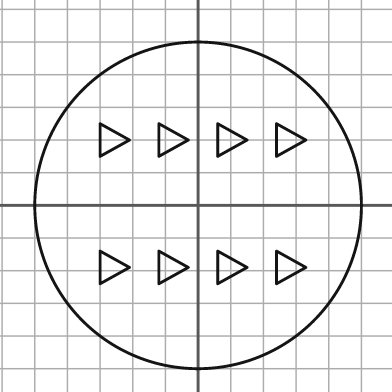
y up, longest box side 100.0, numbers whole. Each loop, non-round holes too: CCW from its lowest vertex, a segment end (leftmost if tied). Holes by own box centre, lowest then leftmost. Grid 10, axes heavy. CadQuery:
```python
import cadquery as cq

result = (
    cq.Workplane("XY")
    .moveTo(0.0, 0.0)
    .circle(50.0)
    .moveTo(-30.0, -24.0)
    .lineTo(-21.0, -19.0)
    .lineTo(-30.0, -14.0)
    .close()
    .moveTo(-12.0, -24.0)
    .lineTo(-3.0, -19.0)
    .lineTo(-12.0, -14.0)
    .close()
    .moveTo(6.0, -24.0)
    .lineTo(15.0, -19.0)
    .lineTo(6.0, -14.0)
    .close()
    .moveTo(24.0, -24.0)
    .lineTo(33.0, -19.0)
    .lineTo(24.0, -14.0)
    .close()
    .moveTo(-30.0, 15.0)
    .lineTo(-21.0, 20.0)
    .lineTo(-30.0, 25.0)
    .close()
    .moveTo(-12.0, 15.0)
    .lineTo(-3.0, 20.0)
    .lineTo(-12.0, 25.0)
    .close()
    .moveTo(6.0, 15.0)
    .lineTo(15.0, 20.0)
    .lineTo(6.0, 25.0)
    .close()
    .moveTo(24.0, 15.0)
    .lineTo(33.0, 20.0)
    .lineTo(24.0, 25.0)
    .close()
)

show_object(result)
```